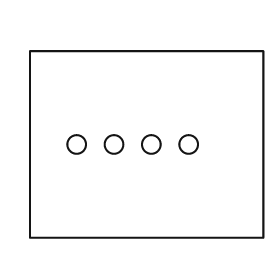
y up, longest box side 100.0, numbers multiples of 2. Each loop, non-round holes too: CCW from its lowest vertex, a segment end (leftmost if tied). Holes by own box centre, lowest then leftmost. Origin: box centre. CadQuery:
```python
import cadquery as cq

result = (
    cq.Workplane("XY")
    .moveTo(-50.0, -40.0)
    .lineTo(50.0, -40.0)
    .lineTo(50.0, 40.0)
    .lineTo(-50.0, 40.0)
    .close()
    .moveTo(-30.0, 0.0)
    .circle(4.0)
    .moveTo(-14.0, 0.0)
    .circle(4.0)
    .moveTo(2.0, 0.0)
    .circle(4.0)
    .moveTo(18.0, 0.0)
    .circle(4.0)
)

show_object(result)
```